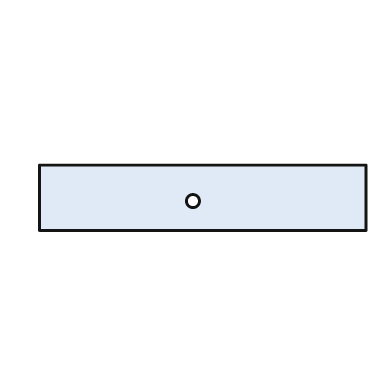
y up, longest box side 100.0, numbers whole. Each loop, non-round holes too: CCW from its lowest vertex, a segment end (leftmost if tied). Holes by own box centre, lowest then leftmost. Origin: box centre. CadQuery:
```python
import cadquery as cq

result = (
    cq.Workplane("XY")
    .moveTo(-50.0, -10.0)
    .lineTo(50.0, -10.0)
    .lineTo(50.0, 10.0)
    .lineTo(-50.0, 10.0)
    .close()
    .moveTo(-3.0, -1.0)
    .circle(2.0)
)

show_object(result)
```